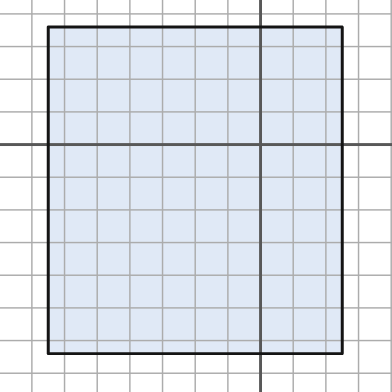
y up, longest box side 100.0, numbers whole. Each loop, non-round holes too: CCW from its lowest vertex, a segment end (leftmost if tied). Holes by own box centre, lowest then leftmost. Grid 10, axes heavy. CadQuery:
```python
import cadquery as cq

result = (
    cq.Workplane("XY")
    .moveTo(-65.0, -64.0)
    .lineTo(25.0, -64.0)
    .lineTo(25.0, 36.0)
    .lineTo(-65.0, 36.0)
    .close()
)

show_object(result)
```